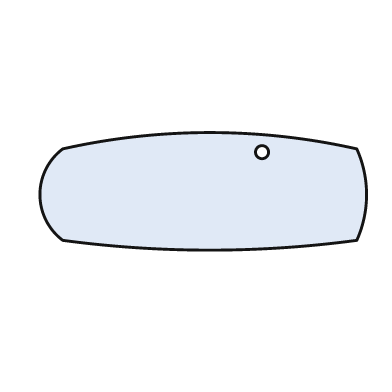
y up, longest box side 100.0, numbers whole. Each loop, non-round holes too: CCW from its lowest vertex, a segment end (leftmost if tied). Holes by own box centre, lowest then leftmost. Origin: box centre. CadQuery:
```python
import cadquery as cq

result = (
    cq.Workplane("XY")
    .moveTo(-43.0, -15.0)
    .threePointArc((2.0, -18.0), (47.0, -15.0))
    .threePointArc((50.0, -1.0), (47.0, 13.0))
    .threePointArc((2.0, 18.0), (-43.0, 13.0))
    .threePointArc((-50.0, -1.0), (-43.0, -15.0))
    .close()
    .moveTo(18.0, 12.0)
    .circle(2.0)
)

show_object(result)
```